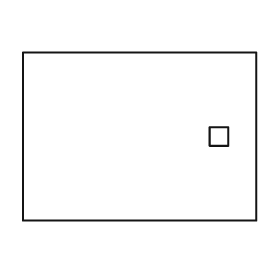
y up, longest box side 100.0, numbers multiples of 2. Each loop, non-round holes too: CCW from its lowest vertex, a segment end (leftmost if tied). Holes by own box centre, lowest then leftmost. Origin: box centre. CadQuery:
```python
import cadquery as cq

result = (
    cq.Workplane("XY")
    .moveTo(-50.0, -36.0)
    .lineTo(50.0, -36.0)
    .lineTo(50.0, 36.0)
    .lineTo(-50.0, 36.0)
    .close()
    .moveTo(30.0, -4.0)
    .lineTo(38.0, -4.0)
    .lineTo(38.0, 4.0)
    .lineTo(30.0, 4.0)
    .close()
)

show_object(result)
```